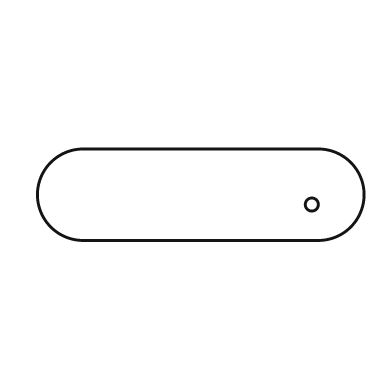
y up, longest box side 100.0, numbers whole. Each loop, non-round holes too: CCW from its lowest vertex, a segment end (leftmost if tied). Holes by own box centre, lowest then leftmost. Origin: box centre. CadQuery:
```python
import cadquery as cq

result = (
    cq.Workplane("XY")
    .moveTo(-36.0, -14.0)
    .lineTo(36.0, -14.0)
    .threePointArc((50.0, 0.0), (36.0, 14.0))
    .lineTo(-36.0, 14.0)
    .threePointArc((-50.0, 0.0), (-36.0, -14.0))
    .close()
    .moveTo(34.0, -3.0)
    .circle(2.0)
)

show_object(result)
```